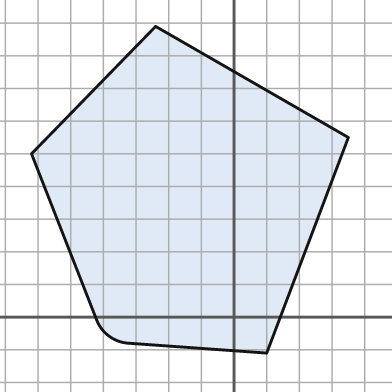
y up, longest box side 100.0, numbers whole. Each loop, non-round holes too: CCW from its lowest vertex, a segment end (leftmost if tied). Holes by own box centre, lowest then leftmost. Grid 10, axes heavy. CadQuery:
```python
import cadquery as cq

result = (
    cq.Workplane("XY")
    .moveTo(10.0, -11.0)
    .lineTo(35.0, 55.0)
    .lineTo(-24.0, 89.0)
    .lineTo(-62.0, 50.0)
    .lineTo(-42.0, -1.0)
    .threePointArc((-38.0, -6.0), (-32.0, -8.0))
    .close()
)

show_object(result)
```